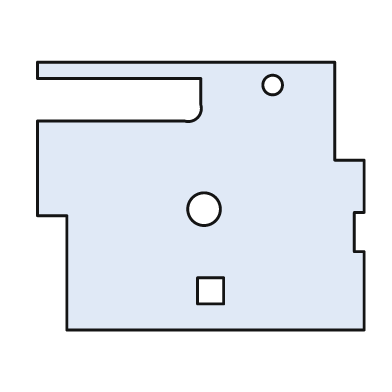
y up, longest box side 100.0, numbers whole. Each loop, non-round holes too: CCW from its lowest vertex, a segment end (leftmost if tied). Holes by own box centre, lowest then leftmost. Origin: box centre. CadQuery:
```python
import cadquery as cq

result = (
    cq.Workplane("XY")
    .moveTo(-41.0, -41.0)
    .lineTo(50.0, -41.0)
    .lineTo(50.0, -17.0)
    .lineTo(47.0, -17.0)
    .lineTo(47.0, -5.0)
    .lineTo(50.0, -5.0)
    .lineTo(50.0, 11.0)
    .lineTo(41.0, 11.0)
    .lineTo(41.0, 41.0)
    .lineTo(-50.0, 41.0)
    .lineTo(-50.0, 36.0)
    .lineTo(0.0, 36.0)
    .lineTo(0.0, 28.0)
    .threePointArc((-1.0, 24.0), (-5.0, 23.0))
    .lineTo(-50.0, 23.0)
    .lineTo(-50.0, -6.0)
    .lineTo(-41.0, -6.0)
    .close()
    .moveTo(-1.0, -33.0)
    .lineTo(7.0, -33.0)
    .lineTo(7.0, -25.0)
    .lineTo(-1.0, -25.0)
    .close()
    .moveTo(1.0, -4.0)
    .circle(5.0)
    .moveTo(22.0, 34.0)
    .circle(3.0)
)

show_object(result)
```